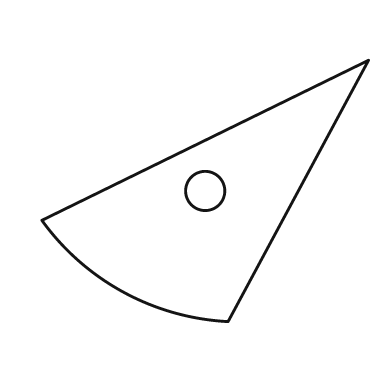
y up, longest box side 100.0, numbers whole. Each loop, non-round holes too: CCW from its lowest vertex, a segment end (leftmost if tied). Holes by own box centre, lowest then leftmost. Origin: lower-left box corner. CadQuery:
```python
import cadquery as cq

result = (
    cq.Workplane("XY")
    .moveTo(57.0, 0.0)
    .lineTo(100.0, 80.0)
    .lineTo(0.0, 31.0)
    .threePointArc((25.0, 9.0), (57.0, 0.0))
    .close()
    .moveTo(50.0, 40.0)
    .circle(6.0)
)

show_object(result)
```